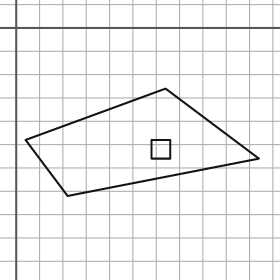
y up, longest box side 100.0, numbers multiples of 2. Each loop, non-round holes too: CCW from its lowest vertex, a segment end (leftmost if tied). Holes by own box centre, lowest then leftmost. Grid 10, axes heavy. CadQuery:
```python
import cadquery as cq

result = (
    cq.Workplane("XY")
    .moveTo(22.0, -72.0)
    .lineTo(104.0, -56.0)
    .lineTo(64.0, -26.0)
    .lineTo(4.0, -48.0)
    .close()
    .moveTo(58.0, -56.0)
    .lineTo(66.0, -56.0)
    .lineTo(66.0, -48.0)
    .lineTo(58.0, -48.0)
    .close()
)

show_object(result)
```